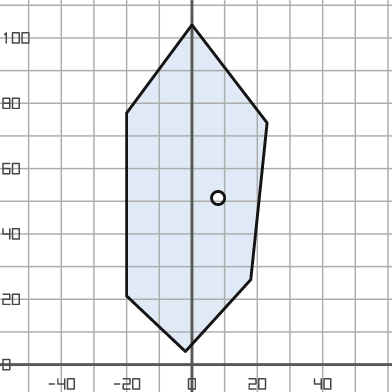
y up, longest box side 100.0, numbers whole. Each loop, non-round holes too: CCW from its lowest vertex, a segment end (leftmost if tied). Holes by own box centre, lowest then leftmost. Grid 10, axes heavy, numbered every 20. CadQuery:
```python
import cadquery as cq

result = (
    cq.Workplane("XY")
    .moveTo(-2.0, 4.0)
    .lineTo(18.0, 26.0)
    .lineTo(23.0, 74.0)
    .lineTo(0.0, 104.0)
    .lineTo(-20.0, 77.0)
    .lineTo(-20.0, 21.0)
    .close()
    .moveTo(8.0, 51.0)
    .circle(2.0)
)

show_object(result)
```